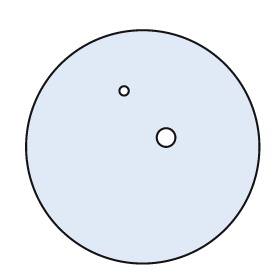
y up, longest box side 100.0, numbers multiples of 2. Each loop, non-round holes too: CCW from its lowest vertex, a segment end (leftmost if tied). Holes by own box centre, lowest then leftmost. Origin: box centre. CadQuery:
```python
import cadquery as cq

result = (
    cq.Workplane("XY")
    .moveTo(0.0, 0.0)
    .circle(50.0)
    .moveTo(10.0, 4.0)
    .circle(4.0)
    .moveTo(-8.0, 24.0)
    .circle(2.0)
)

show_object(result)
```